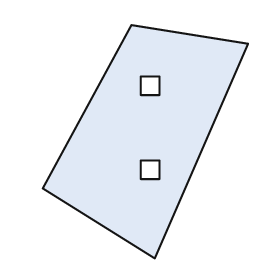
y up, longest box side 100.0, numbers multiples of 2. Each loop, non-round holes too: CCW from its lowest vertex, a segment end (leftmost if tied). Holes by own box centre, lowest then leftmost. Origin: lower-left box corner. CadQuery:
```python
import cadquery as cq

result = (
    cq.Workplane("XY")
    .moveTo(48.0, 0.0)
    .lineTo(88.0, 92.0)
    .lineTo(38.0, 100.0)
    .lineTo(0.0, 30.0)
    .close()
    .moveTo(42.0, 34.0)
    .lineTo(50.0, 34.0)
    .lineTo(50.0, 42.0)
    .lineTo(42.0, 42.0)
    .close()
    .moveTo(42.0, 70.0)
    .lineTo(50.0, 70.0)
    .lineTo(50.0, 78.0)
    .lineTo(42.0, 78.0)
    .close()
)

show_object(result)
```